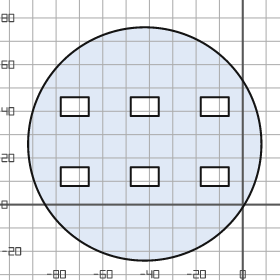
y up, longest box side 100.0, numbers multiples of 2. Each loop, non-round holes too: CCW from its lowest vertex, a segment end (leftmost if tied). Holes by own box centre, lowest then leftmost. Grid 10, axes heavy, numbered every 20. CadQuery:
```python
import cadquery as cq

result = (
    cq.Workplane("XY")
    .moveTo(-42.0, 26.0)
    .circle(50.0)
    .moveTo(-78.0, 8.0)
    .lineTo(-66.0, 8.0)
    .lineTo(-66.0, 16.0)
    .lineTo(-78.0, 16.0)
    .close()
    .moveTo(-48.0, 8.0)
    .lineTo(-36.0, 8.0)
    .lineTo(-36.0, 16.0)
    .lineTo(-48.0, 16.0)
    .close()
    .moveTo(-18.0, 8.0)
    .lineTo(-6.0, 8.0)
    .lineTo(-6.0, 16.0)
    .lineTo(-18.0, 16.0)
    .close()
    .moveTo(-78.0, 38.0)
    .lineTo(-66.0, 38.0)
    .lineTo(-66.0, 46.0)
    .lineTo(-78.0, 46.0)
    .close()
    .moveTo(-48.0, 38.0)
    .lineTo(-36.0, 38.0)
    .lineTo(-36.0, 46.0)
    .lineTo(-48.0, 46.0)
    .close()
    .moveTo(-18.0, 38.0)
    .lineTo(-6.0, 38.0)
    .lineTo(-6.0, 46.0)
    .lineTo(-18.0, 46.0)
    .close()
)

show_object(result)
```